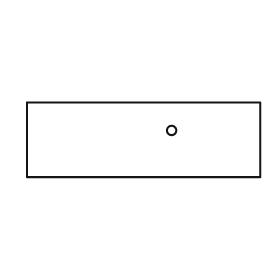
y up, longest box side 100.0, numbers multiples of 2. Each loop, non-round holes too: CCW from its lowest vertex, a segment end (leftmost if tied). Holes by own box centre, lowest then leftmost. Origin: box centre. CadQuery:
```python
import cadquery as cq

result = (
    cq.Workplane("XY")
    .moveTo(-50.0, -16.0)
    .lineTo(50.0, -16.0)
    .lineTo(50.0, 16.0)
    .lineTo(-50.0, 16.0)
    .close()
    .moveTo(12.0, 4.0)
    .circle(2.0)
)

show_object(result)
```